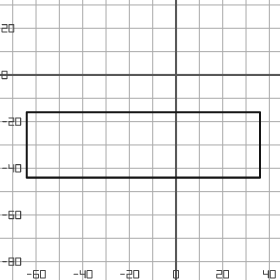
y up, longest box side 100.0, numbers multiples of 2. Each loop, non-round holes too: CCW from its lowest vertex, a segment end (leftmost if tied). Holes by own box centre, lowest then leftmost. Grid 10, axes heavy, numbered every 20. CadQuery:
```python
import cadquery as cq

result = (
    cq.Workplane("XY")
    .moveTo(-64.0, -44.0)
    .lineTo(36.0, -44.0)
    .lineTo(36.0, -16.0)
    .lineTo(-64.0, -16.0)
    .close()
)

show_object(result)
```